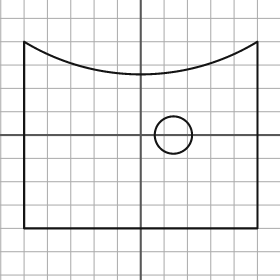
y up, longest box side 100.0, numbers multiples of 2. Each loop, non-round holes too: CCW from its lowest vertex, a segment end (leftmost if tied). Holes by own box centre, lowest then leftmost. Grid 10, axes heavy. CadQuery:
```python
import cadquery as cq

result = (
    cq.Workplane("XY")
    .moveTo(-50.0, -40.0)
    .lineTo(50.0, -40.0)
    .lineTo(50.0, 40.0)
    .threePointArc((0.0, 26.0), (-50.0, 40.0))
    .close()
    .moveTo(14.0, 0.0)
    .circle(8.0)
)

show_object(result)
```